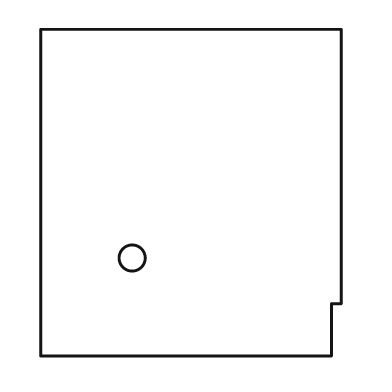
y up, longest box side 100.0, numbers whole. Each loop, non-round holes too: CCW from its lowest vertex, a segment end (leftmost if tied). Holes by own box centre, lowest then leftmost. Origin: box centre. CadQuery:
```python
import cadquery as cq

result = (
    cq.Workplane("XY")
    .moveTo(-46.0, -50.0)
    .lineTo(43.0, -50.0)
    .lineTo(43.0, -34.0)
    .lineTo(46.0, -34.0)
    .lineTo(46.0, 50.0)
    .lineTo(-46.0, 50.0)
    .close()
    .moveTo(-18.0, -20.0)
    .circle(4.0)
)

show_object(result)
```